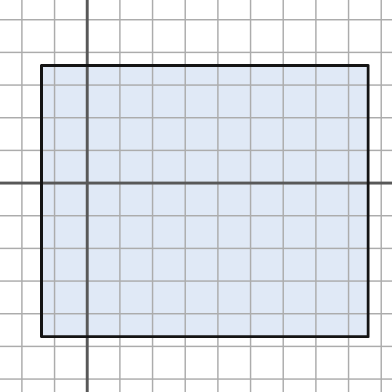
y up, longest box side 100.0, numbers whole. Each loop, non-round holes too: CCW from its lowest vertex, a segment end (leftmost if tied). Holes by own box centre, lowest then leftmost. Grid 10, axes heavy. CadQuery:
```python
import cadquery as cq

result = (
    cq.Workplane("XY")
    .moveTo(-14.0, -47.0)
    .lineTo(86.0, -47.0)
    .lineTo(86.0, 36.0)
    .lineTo(-14.0, 36.0)
    .close()
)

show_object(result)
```